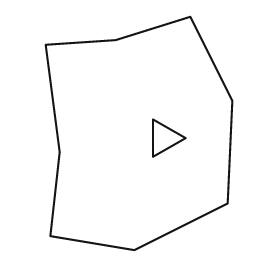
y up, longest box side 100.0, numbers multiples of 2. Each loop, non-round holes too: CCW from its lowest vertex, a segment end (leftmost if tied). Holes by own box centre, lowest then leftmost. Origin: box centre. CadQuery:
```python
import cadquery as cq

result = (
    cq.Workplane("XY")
    .moveTo(-2.0, -50.0)
    .lineTo(38.0, -30.0)
    .lineTo(40.0, 14.0)
    .lineTo(22.0, 50.0)
    .lineTo(-10.0, 40.0)
    .lineTo(-40.0, 38.0)
    .lineTo(-34.0, -8.0)
    .lineTo(-38.0, -44.0)
    .close()
    .moveTo(6.0, -10.0)
    .lineTo(20.0, -2.0)
    .lineTo(6.0, 6.0)
    .close()
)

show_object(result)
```